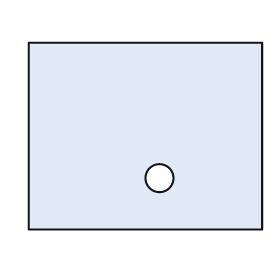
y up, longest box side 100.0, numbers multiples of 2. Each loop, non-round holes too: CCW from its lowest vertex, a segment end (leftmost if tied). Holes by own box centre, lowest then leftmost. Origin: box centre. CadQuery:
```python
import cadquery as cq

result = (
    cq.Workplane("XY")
    .moveTo(-50.0, -40.0)
    .lineTo(50.0, -40.0)
    .lineTo(50.0, 40.0)
    .lineTo(-50.0, 40.0)
    .close()
    .moveTo(6.0, -18.0)
    .circle(6.0)
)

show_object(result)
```